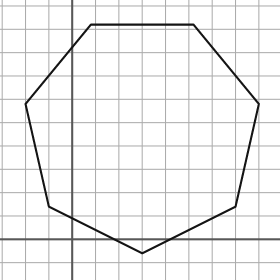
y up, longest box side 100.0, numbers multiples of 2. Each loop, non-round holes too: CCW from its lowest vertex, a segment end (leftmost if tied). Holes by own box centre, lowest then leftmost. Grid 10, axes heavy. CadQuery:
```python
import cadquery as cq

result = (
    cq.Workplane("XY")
    .moveTo(30.0, -6.0)
    .lineTo(70.0, 14.0)
    .lineTo(80.0, 58.0)
    .lineTo(52.0, 92.0)
    .lineTo(8.0, 92.0)
    .lineTo(-20.0, 58.0)
    .lineTo(-10.0, 14.0)
    .close()
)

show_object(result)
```